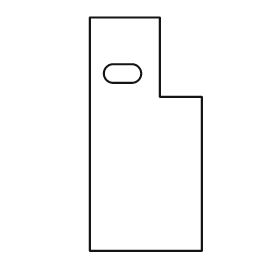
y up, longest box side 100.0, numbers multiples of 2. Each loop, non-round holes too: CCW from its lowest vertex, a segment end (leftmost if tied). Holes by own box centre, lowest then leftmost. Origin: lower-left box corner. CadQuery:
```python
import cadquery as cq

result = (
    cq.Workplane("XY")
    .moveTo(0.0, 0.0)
    .lineTo(48.0, 0.0)
    .lineTo(48.0, 66.0)
    .lineTo(30.0, 66.0)
    .lineTo(30.0, 100.0)
    .lineTo(0.0, 100.0)
    .close()
    .moveTo(10.0, 72.0)
    .lineTo(18.0, 72.0)
    .threePointArc((22.0, 76.0), (18.0, 80.0))
    .lineTo(10.0, 80.0)
    .threePointArc((6.0, 76.0), (10.0, 72.0))
    .close()
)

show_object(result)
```